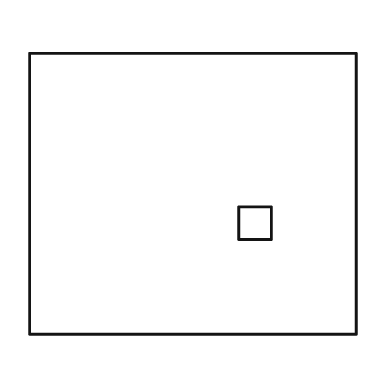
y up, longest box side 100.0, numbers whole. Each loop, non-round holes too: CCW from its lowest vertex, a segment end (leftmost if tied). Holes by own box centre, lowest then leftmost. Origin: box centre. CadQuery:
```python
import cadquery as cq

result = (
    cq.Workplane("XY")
    .moveTo(-50.0, -43.0)
    .lineTo(50.0, -43.0)
    .lineTo(50.0, 43.0)
    .lineTo(-50.0, 43.0)
    .close()
    .moveTo(14.0, -14.0)
    .lineTo(24.0, -14.0)
    .lineTo(24.0, -4.0)
    .lineTo(14.0, -4.0)
    .close()
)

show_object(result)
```